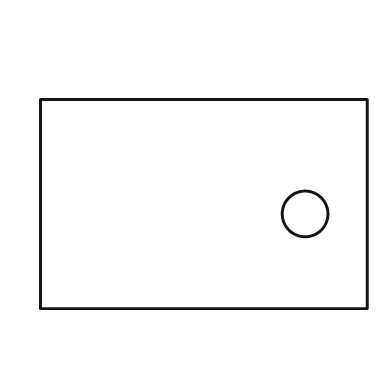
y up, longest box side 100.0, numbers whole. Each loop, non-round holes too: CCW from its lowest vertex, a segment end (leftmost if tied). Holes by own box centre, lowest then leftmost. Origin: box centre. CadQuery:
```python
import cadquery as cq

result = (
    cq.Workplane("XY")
    .moveTo(-50.0, -32.0)
    .lineTo(50.0, -32.0)
    .lineTo(50.0, 32.0)
    .lineTo(-50.0, 32.0)
    .close()
    .moveTo(31.0, -3.0)
    .circle(7.0)
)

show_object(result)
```